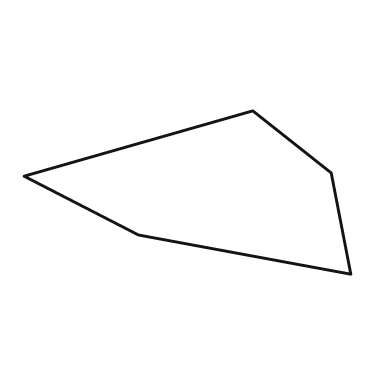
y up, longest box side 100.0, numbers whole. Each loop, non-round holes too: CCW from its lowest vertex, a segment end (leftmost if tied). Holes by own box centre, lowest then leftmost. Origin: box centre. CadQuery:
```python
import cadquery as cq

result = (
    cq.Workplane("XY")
    .moveTo(50.0, -25.0)
    .lineTo(44.0, 6.0)
    .lineTo(20.0, 25.0)
    .lineTo(-50.0, 5.0)
    .lineTo(-15.0, -13.0)
    .close()
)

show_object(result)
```